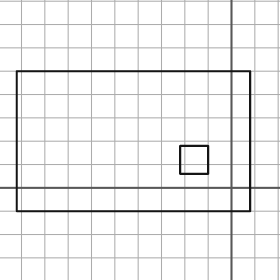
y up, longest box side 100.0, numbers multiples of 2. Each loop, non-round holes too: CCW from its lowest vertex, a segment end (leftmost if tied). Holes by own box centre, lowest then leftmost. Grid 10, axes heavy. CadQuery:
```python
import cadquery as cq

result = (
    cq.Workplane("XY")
    .moveTo(-92.0, -10.0)
    .lineTo(8.0, -10.0)
    .lineTo(8.0, 50.0)
    .lineTo(-92.0, 50.0)
    .close()
    .moveTo(-22.0, 6.0)
    .lineTo(-10.0, 6.0)
    .lineTo(-10.0, 18.0)
    .lineTo(-22.0, 18.0)
    .close()
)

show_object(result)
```